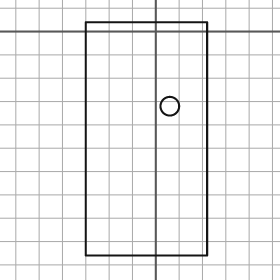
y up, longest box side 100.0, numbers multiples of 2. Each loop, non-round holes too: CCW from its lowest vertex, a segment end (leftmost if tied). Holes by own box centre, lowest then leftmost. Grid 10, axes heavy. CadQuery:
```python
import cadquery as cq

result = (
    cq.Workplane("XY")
    .moveTo(-30.0, -96.0)
    .lineTo(22.0, -96.0)
    .lineTo(22.0, 4.0)
    .lineTo(-30.0, 4.0)
    .close()
    .moveTo(6.0, -32.0)
    .circle(4.0)
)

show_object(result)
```